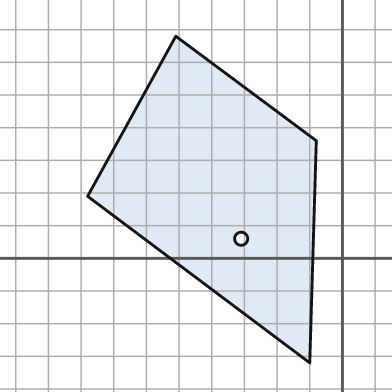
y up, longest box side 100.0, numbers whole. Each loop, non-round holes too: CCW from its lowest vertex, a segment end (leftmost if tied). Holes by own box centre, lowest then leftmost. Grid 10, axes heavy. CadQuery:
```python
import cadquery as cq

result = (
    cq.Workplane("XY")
    .moveTo(-10.0, -32.0)
    .lineTo(-8.0, 36.0)
    .lineTo(-51.0, 68.0)
    .lineTo(-78.0, 19.0)
    .close()
    .moveTo(-31.0, 6.0)
    .circle(2.0)
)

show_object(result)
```